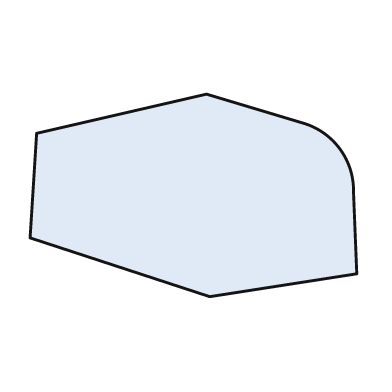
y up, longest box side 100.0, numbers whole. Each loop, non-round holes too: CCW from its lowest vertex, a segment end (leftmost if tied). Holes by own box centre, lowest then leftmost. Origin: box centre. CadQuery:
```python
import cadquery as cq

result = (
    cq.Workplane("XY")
    .moveTo(5.0, -31.0)
    .lineTo(50.0, -24.0)
    .lineTo(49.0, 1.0)
    .threePointArc((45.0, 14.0), (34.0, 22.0))
    .lineTo(4.0, 31.0)
    .lineTo(-48.0, 19.0)
    .lineTo(-50.0, -13.0)
    .close()
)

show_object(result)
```